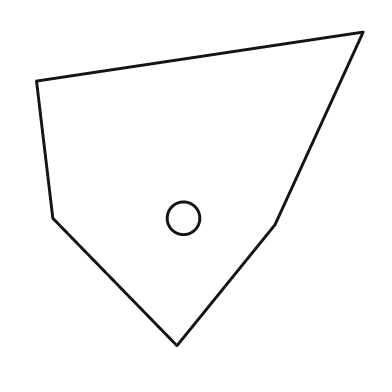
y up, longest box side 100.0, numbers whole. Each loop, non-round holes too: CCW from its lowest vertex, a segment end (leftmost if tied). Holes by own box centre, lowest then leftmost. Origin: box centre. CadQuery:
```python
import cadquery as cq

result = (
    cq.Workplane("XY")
    .moveTo(-7.0, -48.0)
    .lineTo(23.0, -11.0)
    .lineTo(50.0, 48.0)
    .lineTo(-50.0, 33.0)
    .lineTo(-45.0, -9.0)
    .close()
    .moveTo(-5.0, -9.0)
    .circle(5.0)
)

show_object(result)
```